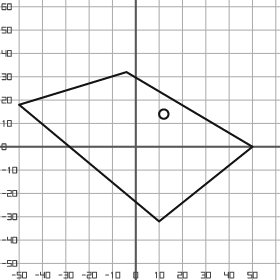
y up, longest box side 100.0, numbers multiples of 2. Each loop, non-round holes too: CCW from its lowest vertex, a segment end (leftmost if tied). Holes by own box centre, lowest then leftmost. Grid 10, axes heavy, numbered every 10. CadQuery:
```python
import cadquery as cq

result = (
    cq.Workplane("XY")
    .moveTo(10.0, -32.0)
    .lineTo(50.0, 0.0)
    .lineTo(-4.0, 32.0)
    .lineTo(-50.0, 18.0)
    .close()
    .moveTo(12.0, 14.0)
    .circle(2.0)
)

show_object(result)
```